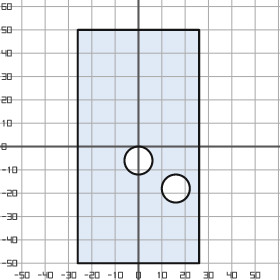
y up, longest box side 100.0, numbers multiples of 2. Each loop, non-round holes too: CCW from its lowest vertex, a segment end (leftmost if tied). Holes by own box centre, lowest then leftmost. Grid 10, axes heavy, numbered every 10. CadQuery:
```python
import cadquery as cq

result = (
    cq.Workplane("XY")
    .moveTo(-26.0, -50.0)
    .lineTo(26.0, -50.0)
    .lineTo(26.0, 50.0)
    .lineTo(-26.0, 50.0)
    .close()
    .moveTo(16.0, -18.0)
    .circle(6.0)
    .moveTo(0.0, -6.0)
    .circle(6.0)
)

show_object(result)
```